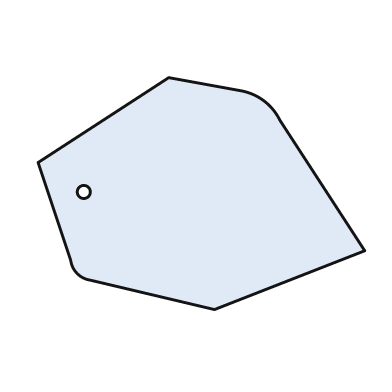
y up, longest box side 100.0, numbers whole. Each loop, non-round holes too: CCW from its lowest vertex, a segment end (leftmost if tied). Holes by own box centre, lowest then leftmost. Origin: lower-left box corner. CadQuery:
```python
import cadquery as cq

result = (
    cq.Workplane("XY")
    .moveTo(54.0, 0.0)
    .lineTo(100.0, 18.0)
    .lineTo(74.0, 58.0)
    .threePointArc((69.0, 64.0), (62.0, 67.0))
    .lineTo(40.0, 71.0)
    .lineTo(0.0, 45.0)
    .lineTo(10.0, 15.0)
    .threePointArc((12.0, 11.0), (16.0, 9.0))
    .close()
    .moveTo(14.0, 36.0)
    .circle(2.0)
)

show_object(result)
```